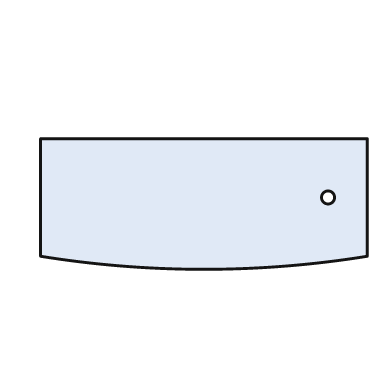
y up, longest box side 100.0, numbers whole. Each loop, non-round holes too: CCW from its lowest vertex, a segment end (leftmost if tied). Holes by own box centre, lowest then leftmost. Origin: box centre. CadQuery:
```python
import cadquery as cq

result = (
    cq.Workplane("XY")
    .moveTo(-50.0, -16.0)
    .threePointArc((0.0, -20.0), (50.0, -16.0))
    .lineTo(50.0, 20.0)
    .lineTo(-50.0, 20.0)
    .close()
    .moveTo(38.0, 2.0)
    .circle(2.0)
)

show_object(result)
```